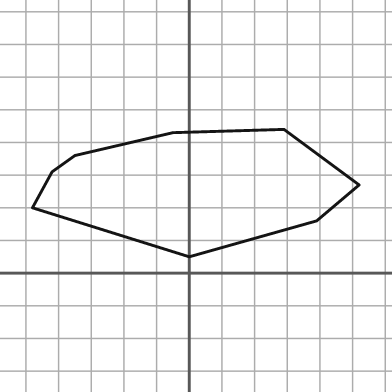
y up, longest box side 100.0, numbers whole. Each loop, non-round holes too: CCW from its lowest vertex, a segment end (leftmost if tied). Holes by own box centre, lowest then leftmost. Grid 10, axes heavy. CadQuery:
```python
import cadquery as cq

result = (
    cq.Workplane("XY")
    .moveTo(0.0, 5.0)
    .lineTo(39.0, 16.0)
    .lineTo(52.0, 27.0)
    .lineTo(29.0, 44.0)
    .lineTo(-5.0, 43.0)
    .lineTo(-35.0, 36.0)
    .lineTo(-42.0, 31.0)
    .lineTo(-48.0, 20.0)
    .close()
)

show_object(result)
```